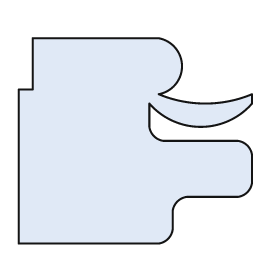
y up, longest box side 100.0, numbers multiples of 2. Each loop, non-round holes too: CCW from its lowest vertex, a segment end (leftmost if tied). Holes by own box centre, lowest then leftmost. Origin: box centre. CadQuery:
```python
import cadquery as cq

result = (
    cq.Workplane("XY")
    .moveTo(-50.0, -44.0)
    .lineTo(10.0, -44.0)
    .threePointArc((14.0, -42.0), (16.0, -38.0))
    .lineTo(16.0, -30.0)
    .threePointArc((18.0, -26.0), (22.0, -24.0))
    .lineTo(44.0, -24.0)
    .threePointArc((48.0, -22.0), (50.0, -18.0))
    .lineTo(50.0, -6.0)
    .threePointArc((48.0, -2.0), (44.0, 0.0))
    .lineTo(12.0, 0.0)
    .threePointArc((8.0, 2.0), (6.0, 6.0))
    .lineTo(6.0, 16.0)
    .threePointArc((28.0, 6.0), (50.0, 16.0))
    .lineTo(50.0, 20.0)
    .threePointArc((30.0, 16.0), (10.0, 20.0))
    .threePointArc((20.0, 32.0), (10.0, 44.0))
    .lineTo(-44.0, 44.0)
    .lineTo(-44.0, 22.0)
    .lineTo(-50.0, 22.0)
    .close()
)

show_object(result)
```